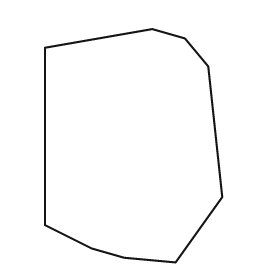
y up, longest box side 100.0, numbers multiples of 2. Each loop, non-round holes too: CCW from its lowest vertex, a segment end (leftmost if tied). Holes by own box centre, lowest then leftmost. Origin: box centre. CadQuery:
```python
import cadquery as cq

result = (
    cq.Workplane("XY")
    .moveTo(18.0, -50.0)
    .lineTo(38.0, -22.0)
    .lineTo(32.0, 34.0)
    .lineTo(22.0, 46.0)
    .lineTo(8.0, 50.0)
    .lineTo(-38.0, 42.0)
    .lineTo(-38.0, -34.0)
    .lineTo(-18.0, -44.0)
    .lineTo(-4.0, -48.0)
    .close()
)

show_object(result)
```